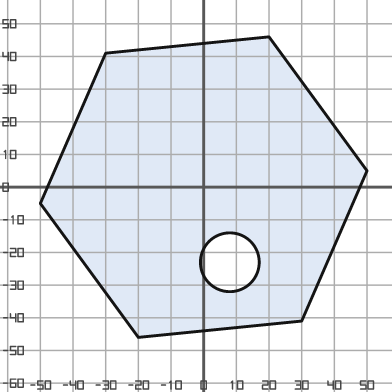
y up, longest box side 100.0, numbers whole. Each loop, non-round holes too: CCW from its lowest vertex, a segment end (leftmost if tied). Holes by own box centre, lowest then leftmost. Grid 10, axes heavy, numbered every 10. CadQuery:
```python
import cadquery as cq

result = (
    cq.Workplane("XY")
    .moveTo(-20.0, -46.0)
    .lineTo(30.0, -41.0)
    .lineTo(50.0, 5.0)
    .lineTo(20.0, 46.0)
    .lineTo(-30.0, 41.0)
    .lineTo(-50.0, -5.0)
    .close()
    .moveTo(8.0, -23.0)
    .circle(9.0)
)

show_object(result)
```